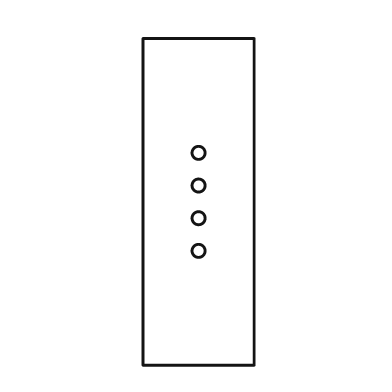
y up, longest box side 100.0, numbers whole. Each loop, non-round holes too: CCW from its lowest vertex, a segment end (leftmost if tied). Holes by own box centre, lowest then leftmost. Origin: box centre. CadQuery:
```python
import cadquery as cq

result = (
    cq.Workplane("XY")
    .moveTo(-17.0, -50.0)
    .lineTo(17.0, -50.0)
    .lineTo(17.0, 50.0)
    .lineTo(-17.0, 50.0)
    .close()
    .moveTo(0.0, -15.0)
    .circle(2.0)
    .moveTo(0.0, -5.0)
    .circle(2.0)
    .moveTo(0.0, 5.0)
    .circle(2.0)
    .moveTo(0.0, 15.0)
    .circle(2.0)
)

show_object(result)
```